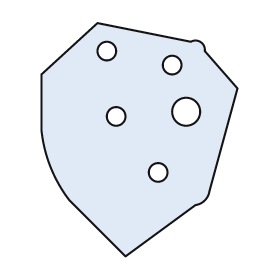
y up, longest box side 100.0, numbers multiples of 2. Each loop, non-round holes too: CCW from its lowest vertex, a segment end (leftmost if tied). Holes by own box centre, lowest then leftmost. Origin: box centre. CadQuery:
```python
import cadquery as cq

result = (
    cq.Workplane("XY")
    .moveTo(-6.0, -50.0)
    .lineTo(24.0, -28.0)
    .threePointArc((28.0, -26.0), (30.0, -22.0))
    .lineTo(42.0, 22.0)
    .lineTo(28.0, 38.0)
    .threePointArc((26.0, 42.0), (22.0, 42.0))
    .lineTo(-18.0, 50.0)
    .lineTo(-42.0, 28.0)
    .lineTo(-42.0, 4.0)
    .threePointArc((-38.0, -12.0), (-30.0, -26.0))
    .close()
    .moveTo(8.0, -14.0)
    .circle(4.0)
    .moveTo(-10.0, 10.0)
    .circle(4.0)
    .moveTo(20.0, 12.0)
    .circle(6.0)
    .moveTo(14.0, 32.0)
    .circle(4.0)
    .moveTo(-14.0, 38.0)
    .circle(4.0)
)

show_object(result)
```